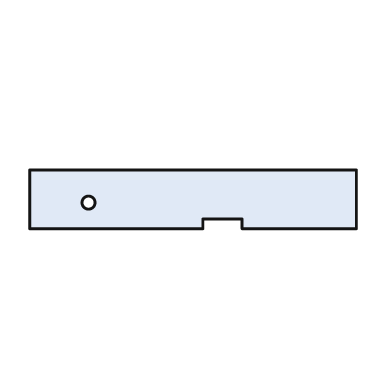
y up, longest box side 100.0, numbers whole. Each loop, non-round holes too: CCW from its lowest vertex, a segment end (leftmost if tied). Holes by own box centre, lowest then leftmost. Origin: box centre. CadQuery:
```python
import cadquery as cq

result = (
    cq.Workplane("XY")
    .moveTo(-50.0, -9.0)
    .lineTo(3.0, -9.0)
    .lineTo(3.0, -6.0)
    .lineTo(15.0, -6.0)
    .lineTo(15.0, -9.0)
    .lineTo(50.0, -9.0)
    .lineTo(50.0, 9.0)
    .lineTo(-50.0, 9.0)
    .close()
    .moveTo(-32.0, -1.0)
    .circle(2.0)
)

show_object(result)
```